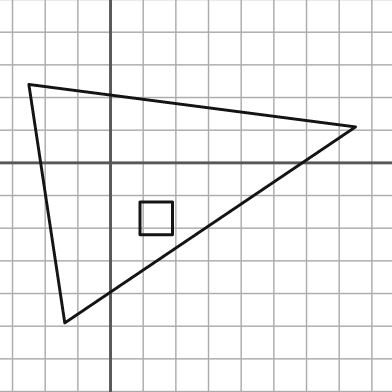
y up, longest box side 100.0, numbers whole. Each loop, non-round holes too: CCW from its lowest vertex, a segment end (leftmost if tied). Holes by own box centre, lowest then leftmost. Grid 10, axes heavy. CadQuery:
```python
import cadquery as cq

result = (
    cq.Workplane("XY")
    .moveTo(-14.0, -49.0)
    .lineTo(75.0, 11.0)
    .lineTo(-25.0, 24.0)
    .close()
    .moveTo(9.0, -22.0)
    .lineTo(19.0, -22.0)
    .lineTo(19.0, -12.0)
    .lineTo(9.0, -12.0)
    .close()
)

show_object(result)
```